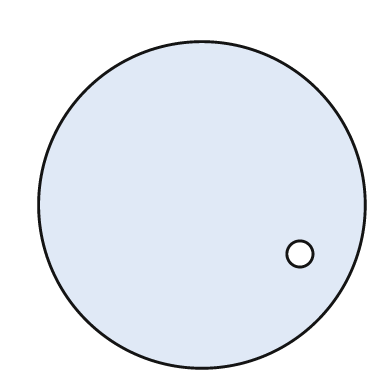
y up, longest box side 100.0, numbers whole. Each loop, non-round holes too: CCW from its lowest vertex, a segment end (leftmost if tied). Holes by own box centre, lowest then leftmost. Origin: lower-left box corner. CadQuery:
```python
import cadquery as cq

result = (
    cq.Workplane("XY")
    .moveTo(50.0, 50.0)
    .circle(50.0)
    .moveTo(80.0, 35.0)
    .circle(4.0)
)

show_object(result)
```